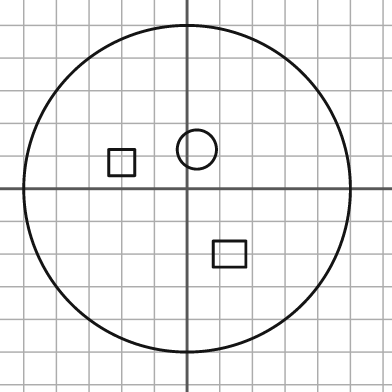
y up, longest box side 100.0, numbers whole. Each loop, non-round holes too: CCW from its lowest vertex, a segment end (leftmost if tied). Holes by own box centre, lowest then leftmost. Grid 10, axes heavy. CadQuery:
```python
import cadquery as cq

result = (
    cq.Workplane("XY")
    .moveTo(0.0, 0.0)
    .circle(50.0)
    .moveTo(8.0, -24.0)
    .lineTo(18.0, -24.0)
    .lineTo(18.0, -16.0)
    .lineTo(8.0, -16.0)
    .close()
    .moveTo(-24.0, 4.0)
    .lineTo(-16.0, 4.0)
    .lineTo(-16.0, 12.0)
    .lineTo(-24.0, 12.0)
    .close()
    .moveTo(3.0, 12.0)
    .circle(6.0)
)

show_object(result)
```